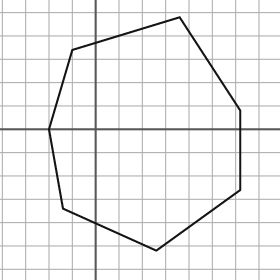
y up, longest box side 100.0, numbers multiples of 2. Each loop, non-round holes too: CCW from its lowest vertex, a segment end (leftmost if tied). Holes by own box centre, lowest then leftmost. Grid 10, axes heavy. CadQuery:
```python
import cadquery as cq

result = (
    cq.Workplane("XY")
    .moveTo(26.0, -52.0)
    .lineTo(62.0, -26.0)
    .lineTo(62.0, 8.0)
    .lineTo(36.0, 48.0)
    .lineTo(-10.0, 34.0)
    .lineTo(-20.0, 0.0)
    .lineTo(-14.0, -34.0)
    .close()
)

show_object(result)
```